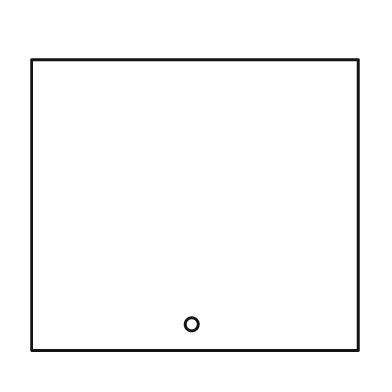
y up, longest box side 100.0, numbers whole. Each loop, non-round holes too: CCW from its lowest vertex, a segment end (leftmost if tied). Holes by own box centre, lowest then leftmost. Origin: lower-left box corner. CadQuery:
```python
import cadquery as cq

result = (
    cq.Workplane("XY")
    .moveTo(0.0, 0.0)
    .lineTo(100.0, 0.0)
    .lineTo(100.0, 89.0)
    .lineTo(0.0, 89.0)
    .close()
    .moveTo(49.0, 8.0)
    .circle(2.0)
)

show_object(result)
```